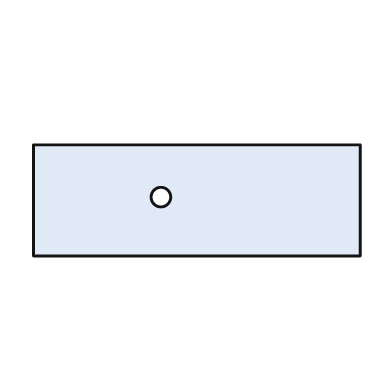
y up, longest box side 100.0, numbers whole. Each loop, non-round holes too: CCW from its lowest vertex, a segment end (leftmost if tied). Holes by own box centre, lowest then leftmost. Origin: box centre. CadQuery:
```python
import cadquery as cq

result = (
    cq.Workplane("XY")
    .moveTo(-50.0, -17.0)
    .lineTo(50.0, -17.0)
    .lineTo(50.0, 17.0)
    .lineTo(-50.0, 17.0)
    .close()
    .moveTo(-11.0, 1.0)
    .circle(3.0)
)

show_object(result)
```